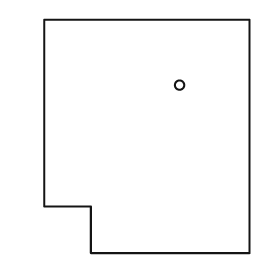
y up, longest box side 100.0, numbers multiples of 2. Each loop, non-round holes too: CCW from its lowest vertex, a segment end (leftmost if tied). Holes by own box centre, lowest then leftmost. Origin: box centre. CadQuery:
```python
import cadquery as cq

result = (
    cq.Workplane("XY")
    .moveTo(-24.0, -50.0)
    .lineTo(44.0, -50.0)
    .lineTo(44.0, 50.0)
    .lineTo(-44.0, 50.0)
    .lineTo(-44.0, -30.0)
    .lineTo(-24.0, -30.0)
    .close()
    .moveTo(14.0, 22.0)
    .circle(2.0)
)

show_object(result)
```